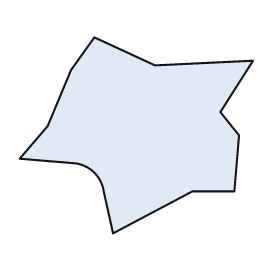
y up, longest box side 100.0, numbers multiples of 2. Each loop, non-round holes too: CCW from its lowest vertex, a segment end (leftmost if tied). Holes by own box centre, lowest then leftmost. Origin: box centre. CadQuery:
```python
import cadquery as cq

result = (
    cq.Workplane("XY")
    .moveTo(-10.0, -42.0)
    .lineTo(24.0, -24.0)
    .lineTo(42.0, -24.0)
    .lineTo(44.0, 0.0)
    .lineTo(36.0, 10.0)
    .lineTo(50.0, 32.0)
    .lineTo(8.0, 30.0)
    .lineTo(-18.0, 42.0)
    .lineTo(-28.0, 28.0)
    .lineTo(-38.0, 4.0)
    .lineTo(-50.0, -10.0)
    .lineTo(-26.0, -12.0)
    .threePointArc((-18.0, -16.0), (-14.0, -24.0))
    .close()
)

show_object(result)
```